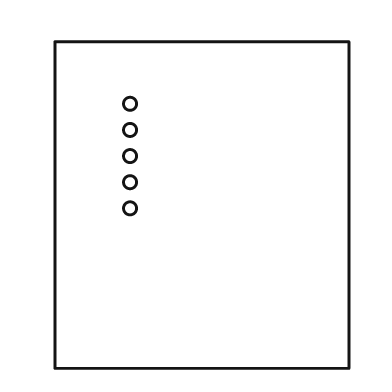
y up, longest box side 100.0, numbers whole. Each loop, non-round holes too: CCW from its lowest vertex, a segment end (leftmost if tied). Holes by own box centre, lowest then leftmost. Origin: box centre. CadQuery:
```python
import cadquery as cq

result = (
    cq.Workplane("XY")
    .moveTo(-45.0, -50.0)
    .lineTo(45.0, -50.0)
    .lineTo(45.0, 50.0)
    .lineTo(-45.0, 50.0)
    .close()
    .moveTo(-22.0, -1.0)
    .circle(2.0)
    .moveTo(-22.0, 7.0)
    .circle(2.0)
    .moveTo(-22.0, 15.0)
    .circle(2.0)
    .moveTo(-22.0, 23.0)
    .circle(2.0)
    .moveTo(-22.0, 31.0)
    .circle(2.0)
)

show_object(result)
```